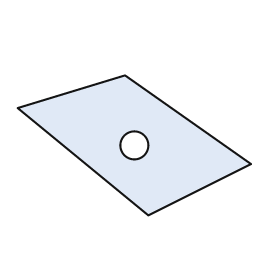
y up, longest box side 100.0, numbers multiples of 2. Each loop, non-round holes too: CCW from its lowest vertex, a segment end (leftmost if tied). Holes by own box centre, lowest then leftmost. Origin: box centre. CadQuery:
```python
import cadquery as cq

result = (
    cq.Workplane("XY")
    .moveTo(6.0, -30.0)
    .lineTo(50.0, -8.0)
    .lineTo(-4.0, 30.0)
    .lineTo(-50.0, 16.0)
    .close()
    .moveTo(0.0, 0.0)
    .circle(6.0)
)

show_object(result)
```